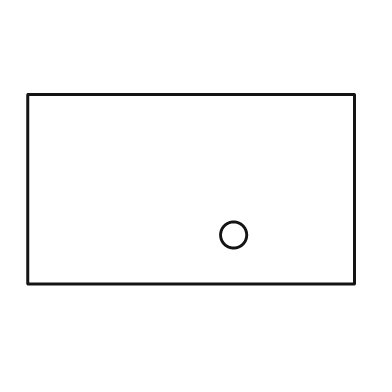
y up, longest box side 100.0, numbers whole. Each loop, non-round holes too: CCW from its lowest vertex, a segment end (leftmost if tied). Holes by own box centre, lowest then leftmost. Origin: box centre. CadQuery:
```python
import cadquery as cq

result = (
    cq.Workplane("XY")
    .moveTo(-50.0, -29.0)
    .lineTo(50.0, -29.0)
    .lineTo(50.0, 29.0)
    .lineTo(-50.0, 29.0)
    .close()
    .moveTo(13.0, -14.0)
    .circle(4.0)
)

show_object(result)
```